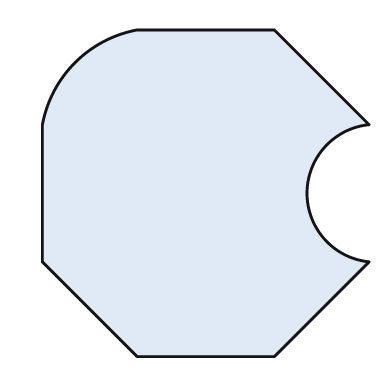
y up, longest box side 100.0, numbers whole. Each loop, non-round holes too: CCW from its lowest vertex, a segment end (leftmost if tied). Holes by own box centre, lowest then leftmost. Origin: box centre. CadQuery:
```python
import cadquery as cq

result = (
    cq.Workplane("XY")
    .moveTo(-21.0, -50.0)
    .lineTo(21.0, -50.0)
    .lineTo(50.0, -21.0)
    .threePointArc((31.0, 0.0), (50.0, 21.0))
    .lineTo(21.0, 50.0)
    .lineTo(-21.0, 50.0)
    .threePointArc((-40.0, 40.0), (-50.0, 21.0))
    .lineTo(-50.0, -21.0)
    .close()
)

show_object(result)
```